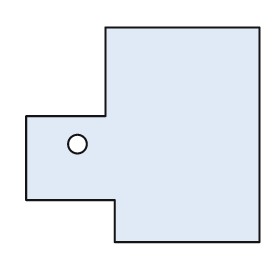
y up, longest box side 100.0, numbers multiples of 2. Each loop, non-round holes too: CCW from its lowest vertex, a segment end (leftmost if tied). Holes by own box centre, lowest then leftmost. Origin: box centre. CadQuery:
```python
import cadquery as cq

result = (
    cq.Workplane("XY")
    .moveTo(-12.0, -46.0)
    .lineTo(50.0, -46.0)
    .lineTo(50.0, 46.0)
    .lineTo(-16.0, 46.0)
    .lineTo(-16.0, 8.0)
    .lineTo(-50.0, 8.0)
    .lineTo(-50.0, -28.0)
    .lineTo(-12.0, -28.0)
    .close()
    .moveTo(-28.0, -4.0)
    .circle(4.0)
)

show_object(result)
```